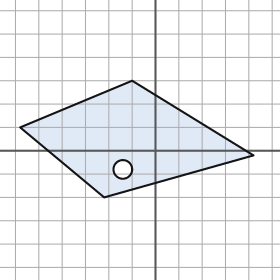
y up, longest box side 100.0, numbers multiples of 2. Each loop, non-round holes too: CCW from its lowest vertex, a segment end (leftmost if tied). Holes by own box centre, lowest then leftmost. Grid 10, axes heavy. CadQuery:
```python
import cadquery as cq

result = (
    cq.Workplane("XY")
    .moveTo(-22.0, -20.0)
    .lineTo(42.0, -2.0)
    .lineTo(-10.0, 30.0)
    .lineTo(-58.0, 10.0)
    .close()
    .moveTo(-14.0, -8.0)
    .circle(4.0)
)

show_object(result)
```